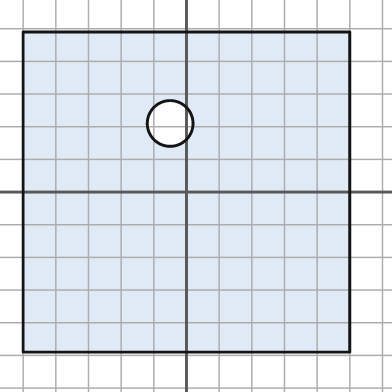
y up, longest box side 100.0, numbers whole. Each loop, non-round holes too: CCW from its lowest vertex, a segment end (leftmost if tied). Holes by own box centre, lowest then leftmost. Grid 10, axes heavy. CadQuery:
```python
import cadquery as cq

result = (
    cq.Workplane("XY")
    .moveTo(-50.0, -49.0)
    .lineTo(50.0, -49.0)
    .lineTo(50.0, 49.0)
    .lineTo(-50.0, 49.0)
    .close()
    .moveTo(-5.0, 21.0)
    .circle(7.0)
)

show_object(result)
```